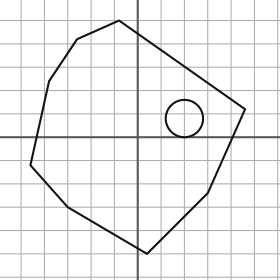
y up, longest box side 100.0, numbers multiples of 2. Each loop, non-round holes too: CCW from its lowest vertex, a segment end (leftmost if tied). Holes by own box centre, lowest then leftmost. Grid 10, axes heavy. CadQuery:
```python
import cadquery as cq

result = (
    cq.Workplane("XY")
    .moveTo(4.0, -50.0)
    .lineTo(30.0, -24.0)
    .lineTo(46.0, 12.0)
    .lineTo(-8.0, 50.0)
    .lineTo(-26.0, 42.0)
    .lineTo(-38.0, 24.0)
    .lineTo(-46.0, -12.0)
    .lineTo(-30.0, -30.0)
    .close()
    .moveTo(20.0, 8.0)
    .circle(8.0)
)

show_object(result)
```